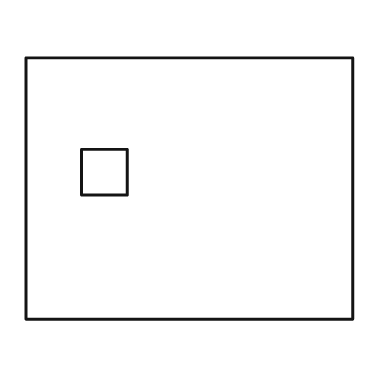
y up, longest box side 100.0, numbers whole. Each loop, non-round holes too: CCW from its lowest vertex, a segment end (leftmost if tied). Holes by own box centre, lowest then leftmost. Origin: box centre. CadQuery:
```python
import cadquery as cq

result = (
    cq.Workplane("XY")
    .moveTo(-50.0, -40.0)
    .lineTo(50.0, -40.0)
    .lineTo(50.0, 40.0)
    .lineTo(-50.0, 40.0)
    .close()
    .moveTo(-33.0, -2.0)
    .lineTo(-19.0, -2.0)
    .lineTo(-19.0, 12.0)
    .lineTo(-33.0, 12.0)
    .close()
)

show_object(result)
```